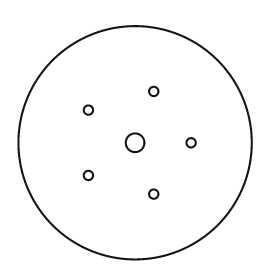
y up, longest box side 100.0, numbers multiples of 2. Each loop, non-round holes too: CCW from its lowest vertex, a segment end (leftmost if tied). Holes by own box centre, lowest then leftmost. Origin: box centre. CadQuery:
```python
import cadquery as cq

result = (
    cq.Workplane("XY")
    .moveTo(0.0, 0.0)
    .circle(50.0)
    .moveTo(8.0, -22.0)
    .circle(2.0)
    .moveTo(-20.0, -14.0)
    .circle(2.0)
    .moveTo(0.0, 0.0)
    .circle(4.0)
    .moveTo(24.0, 0.0)
    .circle(2.0)
    .moveTo(-20.0, 14.0)
    .circle(2.0)
    .moveTo(8.0, 22.0)
    .circle(2.0)
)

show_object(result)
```